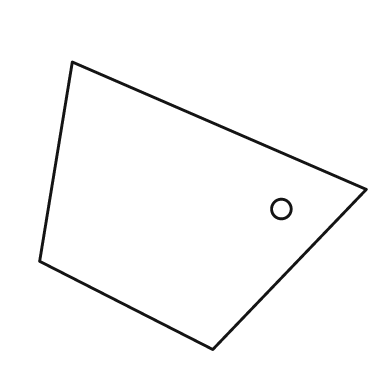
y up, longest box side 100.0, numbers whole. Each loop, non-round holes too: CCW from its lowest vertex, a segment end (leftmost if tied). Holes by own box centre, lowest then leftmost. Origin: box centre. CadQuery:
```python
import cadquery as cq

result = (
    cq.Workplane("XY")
    .moveTo(3.0, -44.0)
    .lineTo(50.0, 5.0)
    .lineTo(-40.0, 44.0)
    .lineTo(-50.0, -17.0)
    .close()
    .moveTo(24.0, -1.0)
    .circle(3.0)
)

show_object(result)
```